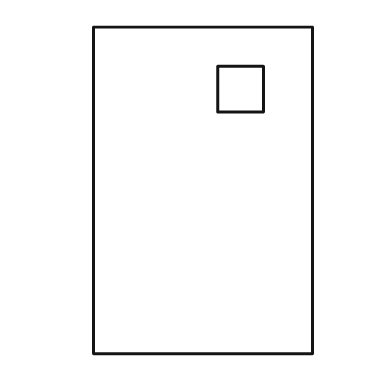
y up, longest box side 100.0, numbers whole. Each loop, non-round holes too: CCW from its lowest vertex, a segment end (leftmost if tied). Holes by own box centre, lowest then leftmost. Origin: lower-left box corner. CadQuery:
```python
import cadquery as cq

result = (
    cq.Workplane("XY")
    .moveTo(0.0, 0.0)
    .lineTo(67.0, 0.0)
    .lineTo(67.0, 100.0)
    .lineTo(0.0, 100.0)
    .close()
    .moveTo(38.0, 74.0)
    .lineTo(52.0, 74.0)
    .lineTo(52.0, 88.0)
    .lineTo(38.0, 88.0)
    .close()
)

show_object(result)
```